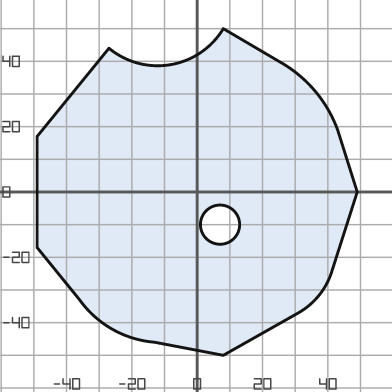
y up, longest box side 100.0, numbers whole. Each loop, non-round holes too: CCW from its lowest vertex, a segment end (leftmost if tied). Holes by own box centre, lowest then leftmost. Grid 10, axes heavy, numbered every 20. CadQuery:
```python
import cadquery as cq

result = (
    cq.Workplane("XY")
    .moveTo(8.0, -50.0)
    .lineTo(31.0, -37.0)
    .threePointArc((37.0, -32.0), (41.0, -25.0))
    .lineTo(49.0, 0.0)
    .lineTo(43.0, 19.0)
    .threePointArc((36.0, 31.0), (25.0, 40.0))
    .lineTo(8.0, 50.0)
    .threePointArc((-8.0, 39.0), (-27.0, 44.0))
    .lineTo(-49.0, 17.0)
    .lineTo(-49.0, -17.0)
    .lineTo(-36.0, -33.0)
    .threePointArc((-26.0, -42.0), (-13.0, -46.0))
    .close()
    .moveTo(7.0, -10.0)
    .circle(6.0)
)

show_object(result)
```